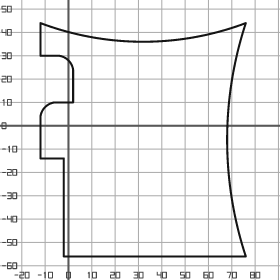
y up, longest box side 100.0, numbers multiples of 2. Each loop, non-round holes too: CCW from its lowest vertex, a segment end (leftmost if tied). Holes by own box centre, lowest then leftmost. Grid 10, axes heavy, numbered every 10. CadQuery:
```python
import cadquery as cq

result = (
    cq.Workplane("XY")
    .moveTo(-2.0, -56.0)
    .lineTo(76.0, -56.0)
    .threePointArc((68.0, -6.0), (76.0, 44.0))
    .threePointArc((32.0, 36.0), (-12.0, 44.0))
    .lineTo(-12.0, 30.0)
    .lineTo(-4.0, 30.0)
    .threePointArc((0.0, 28.0), (2.0, 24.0))
    .lineTo(2.0, 10.0)
    .lineTo(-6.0, 10.0)
    .threePointArc((-10.0, 8.0), (-12.0, 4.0))
    .lineTo(-12.0, -14.0)
    .lineTo(-2.0, -14.0)
    .close()
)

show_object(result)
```